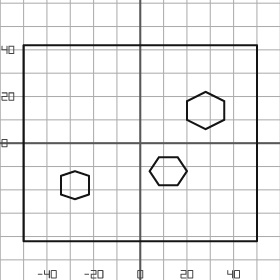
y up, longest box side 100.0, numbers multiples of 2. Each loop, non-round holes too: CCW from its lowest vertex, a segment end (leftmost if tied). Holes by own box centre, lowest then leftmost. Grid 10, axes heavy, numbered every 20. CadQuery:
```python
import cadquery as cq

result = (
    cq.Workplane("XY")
    .moveTo(-50.0, -42.0)
    .lineTo(50.0, -42.0)
    .lineTo(50.0, 42.0)
    .lineTo(-50.0, 42.0)
    .close()
    .moveTo(-28.0, -24.0)
    .lineTo(-22.0, -22.0)
    .lineTo(-22.0, -14.0)
    .lineTo(-28.0, -12.0)
    .lineTo(-34.0, -14.0)
    .lineTo(-34.0, -22.0)
    .close()
    .moveTo(8.0, -18.0)
    .lineTo(16.0, -18.0)
    .lineTo(20.0, -12.0)
    .lineTo(16.0, -6.0)
    .lineTo(8.0, -6.0)
    .lineTo(4.0, -12.0)
    .close()
    .moveTo(28.0, 6.0)
    .lineTo(36.0, 10.0)
    .lineTo(36.0, 18.0)
    .lineTo(28.0, 22.0)
    .lineTo(20.0, 18.0)
    .lineTo(20.0, 10.0)
    .close()
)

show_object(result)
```